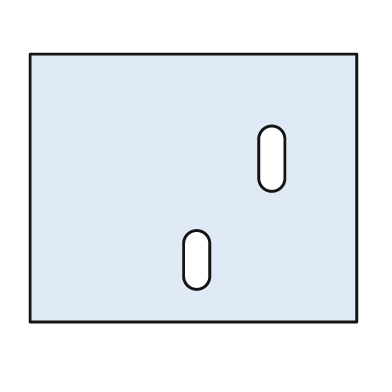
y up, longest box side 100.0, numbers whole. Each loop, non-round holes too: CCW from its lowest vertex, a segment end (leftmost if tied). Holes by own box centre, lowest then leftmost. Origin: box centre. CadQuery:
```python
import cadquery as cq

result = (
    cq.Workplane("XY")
    .moveTo(-50.0, -41.0)
    .lineTo(50.0, -41.0)
    .lineTo(50.0, 41.0)
    .lineTo(-50.0, 41.0)
    .close()
    .moveTo(-3.0, -27.0)
    .threePointArc((1.0, -31.0), (5.0, -27.0))
    .lineTo(5.0, -17.0)
    .threePointArc((1.0, -13.0), (-3.0, -17.0))
    .close()
    .moveTo(20.0, 3.0)
    .threePointArc((24.0, -1.0), (28.0, 3.0))
    .lineTo(28.0, 15.0)
    .threePointArc((24.0, 19.0), (20.0, 15.0))
    .close()
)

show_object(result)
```